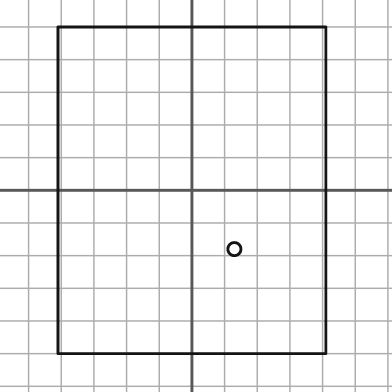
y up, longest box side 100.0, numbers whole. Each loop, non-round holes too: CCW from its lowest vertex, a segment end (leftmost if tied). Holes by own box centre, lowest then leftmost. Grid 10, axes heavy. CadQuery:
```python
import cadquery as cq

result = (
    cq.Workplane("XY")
    .moveTo(-41.0, -50.0)
    .lineTo(41.0, -50.0)
    .lineTo(41.0, 50.0)
    .lineTo(-41.0, 50.0)
    .close()
    .moveTo(13.0, -18.0)
    .circle(2.0)
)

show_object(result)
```